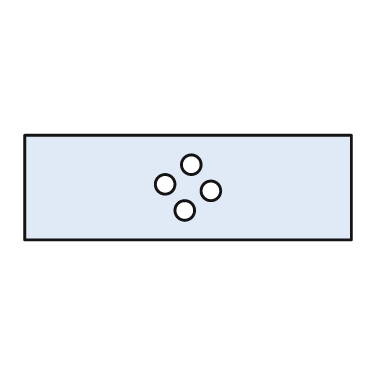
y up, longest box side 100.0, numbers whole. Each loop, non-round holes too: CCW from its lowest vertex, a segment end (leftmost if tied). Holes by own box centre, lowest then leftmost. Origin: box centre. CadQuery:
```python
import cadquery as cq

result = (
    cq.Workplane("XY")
    .moveTo(-50.0, -16.0)
    .lineTo(50.0, -16.0)
    .lineTo(50.0, 16.0)
    .lineTo(-50.0, 16.0)
    .close()
    .moveTo(-1.0, -7.0)
    .circle(3.0)
    .moveTo(7.0, -1.0)
    .circle(3.0)
    .moveTo(-7.0, 1.0)
    .circle(3.0)
    .moveTo(1.0, 7.0)
    .circle(3.0)
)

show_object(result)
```